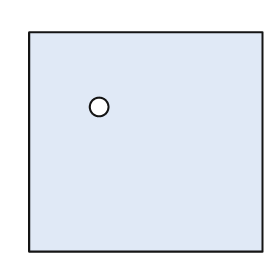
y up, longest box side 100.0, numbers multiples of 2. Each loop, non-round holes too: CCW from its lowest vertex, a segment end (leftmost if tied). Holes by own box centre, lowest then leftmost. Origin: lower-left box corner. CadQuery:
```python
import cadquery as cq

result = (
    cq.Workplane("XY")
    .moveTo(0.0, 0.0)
    .lineTo(100.0, 0.0)
    .lineTo(100.0, 94.0)
    .lineTo(0.0, 94.0)
    .close()
    .moveTo(30.0, 62.0)
    .circle(4.0)
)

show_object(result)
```